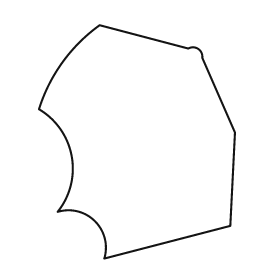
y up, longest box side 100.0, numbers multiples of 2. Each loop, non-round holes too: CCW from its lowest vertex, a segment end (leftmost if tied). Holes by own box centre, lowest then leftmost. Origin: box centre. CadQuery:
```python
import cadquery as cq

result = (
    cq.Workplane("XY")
    .moveTo(-14.0, -50.0)
    .lineTo(40.0, -36.0)
    .lineTo(42.0, 4.0)
    .lineTo(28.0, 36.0)
    .threePointArc((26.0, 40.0), (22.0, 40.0))
    .lineTo(-16.0, 50.0)
    .threePointArc((-32.0, 34.0), (-42.0, 14.0))
    .threePointArc((-28.0, -6.0), (-34.0, -30.0))
    .threePointArc((-18.0, -34.0), (-14.0, -50.0))
    .close()
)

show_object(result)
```